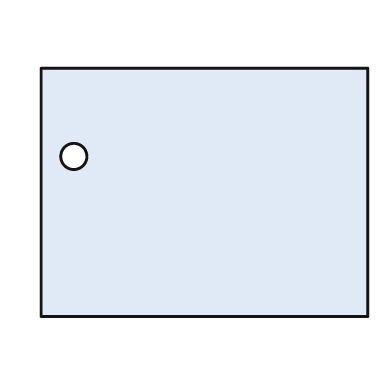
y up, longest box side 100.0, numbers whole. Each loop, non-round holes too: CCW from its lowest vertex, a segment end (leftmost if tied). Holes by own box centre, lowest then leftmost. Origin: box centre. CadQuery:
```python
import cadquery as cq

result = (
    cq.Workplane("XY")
    .moveTo(-50.0, -38.0)
    .lineTo(50.0, -38.0)
    .lineTo(50.0, 38.0)
    .lineTo(-50.0, 38.0)
    .close()
    .moveTo(-40.0, 11.0)
    .circle(4.0)
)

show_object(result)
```